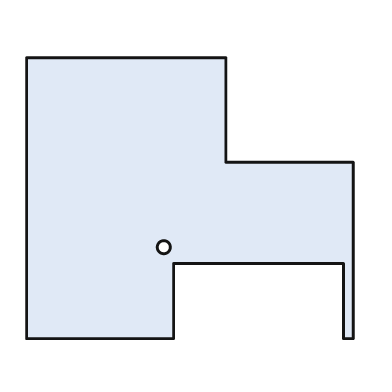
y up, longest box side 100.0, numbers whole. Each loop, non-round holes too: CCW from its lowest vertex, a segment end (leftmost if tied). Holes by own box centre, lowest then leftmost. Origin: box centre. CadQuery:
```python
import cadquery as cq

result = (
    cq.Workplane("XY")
    .moveTo(-50.0, -43.0)
    .lineTo(-5.0, -43.0)
    .lineTo(-5.0, -20.0)
    .lineTo(47.0, -20.0)
    .lineTo(47.0, -43.0)
    .lineTo(50.0, -43.0)
    .lineTo(50.0, 11.0)
    .lineTo(11.0, 11.0)
    .lineTo(11.0, 43.0)
    .lineTo(-50.0, 43.0)
    .close()
    .moveTo(-8.0, -15.0)
    .circle(2.0)
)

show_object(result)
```